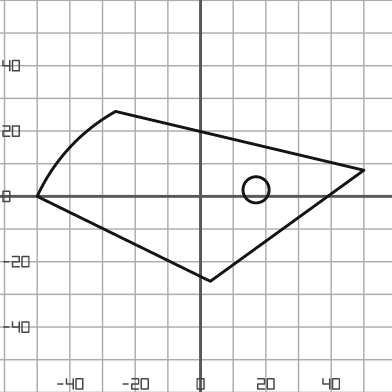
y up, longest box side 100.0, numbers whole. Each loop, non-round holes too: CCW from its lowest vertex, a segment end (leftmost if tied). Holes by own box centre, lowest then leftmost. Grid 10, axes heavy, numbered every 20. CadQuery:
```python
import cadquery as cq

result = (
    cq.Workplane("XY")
    .moveTo(3.0, -26.0)
    .lineTo(50.0, 8.0)
    .lineTo(-26.0, 26.0)
    .threePointArc((-40.0, 15.0), (-50.0, 0.0))
    .close()
    .moveTo(17.0, 2.0)
    .circle(4.0)
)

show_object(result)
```